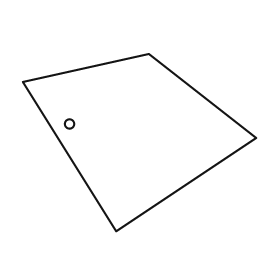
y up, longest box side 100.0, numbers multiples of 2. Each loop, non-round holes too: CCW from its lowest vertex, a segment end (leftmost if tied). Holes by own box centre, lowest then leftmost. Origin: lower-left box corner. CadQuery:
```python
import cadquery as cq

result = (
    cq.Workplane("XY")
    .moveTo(40.0, 0.0)
    .lineTo(100.0, 40.0)
    .lineTo(54.0, 76.0)
    .lineTo(0.0, 64.0)
    .close()
    .moveTo(20.0, 46.0)
    .circle(2.0)
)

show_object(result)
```